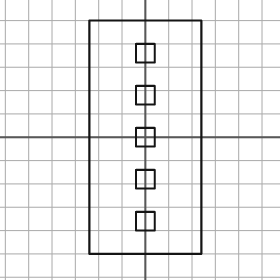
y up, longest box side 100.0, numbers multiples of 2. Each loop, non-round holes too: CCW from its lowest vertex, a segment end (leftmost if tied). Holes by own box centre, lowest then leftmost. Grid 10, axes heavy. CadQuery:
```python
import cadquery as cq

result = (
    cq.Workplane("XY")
    .moveTo(-24.0, -50.0)
    .lineTo(24.0, -50.0)
    .lineTo(24.0, 50.0)
    .lineTo(-24.0, 50.0)
    .close()
    .moveTo(-4.0, -40.0)
    .lineTo(4.0, -40.0)
    .lineTo(4.0, -32.0)
    .lineTo(-4.0, -32.0)
    .close()
    .moveTo(-4.0, -22.0)
    .lineTo(4.0, -22.0)
    .lineTo(4.0, -14.0)
    .lineTo(-4.0, -14.0)
    .close()
    .moveTo(-4.0, -4.0)
    .lineTo(4.0, -4.0)
    .lineTo(4.0, 4.0)
    .lineTo(-4.0, 4.0)
    .close()
    .moveTo(-4.0, 14.0)
    .lineTo(4.0, 14.0)
    .lineTo(4.0, 22.0)
    .lineTo(-4.0, 22.0)
    .close()
    .moveTo(-4.0, 32.0)
    .lineTo(4.0, 32.0)
    .lineTo(4.0, 40.0)
    .lineTo(-4.0, 40.0)
    .close()
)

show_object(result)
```